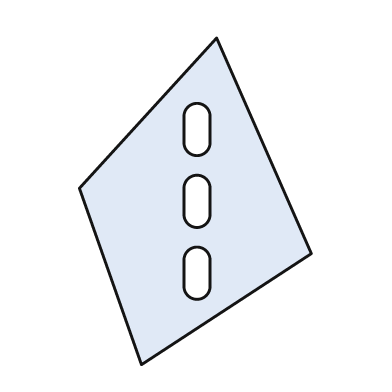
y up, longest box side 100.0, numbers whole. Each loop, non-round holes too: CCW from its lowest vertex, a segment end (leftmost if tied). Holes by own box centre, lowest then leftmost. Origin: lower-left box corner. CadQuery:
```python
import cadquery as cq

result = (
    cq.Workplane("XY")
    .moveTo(19.0, 0.0)
    .lineTo(71.0, 34.0)
    .lineTo(42.0, 100.0)
    .lineTo(0.0, 54.0)
    .close()
    .moveTo(32.0, 24.0)
    .threePointArc((36.0, 20.0), (40.0, 24.0))
    .lineTo(40.0, 32.0)
    .threePointArc((36.0, 36.0), (32.0, 32.0))
    .close()
    .moveTo(32.0, 46.0)
    .threePointArc((36.0, 42.0), (40.0, 46.0))
    .lineTo(40.0, 54.0)
    .threePointArc((36.0, 58.0), (32.0, 54.0))
    .close()
    .moveTo(32.0, 68.0)
    .threePointArc((36.0, 64.0), (40.0, 68.0))
    .lineTo(40.0, 76.0)
    .threePointArc((36.0, 80.0), (32.0, 76.0))
    .close()
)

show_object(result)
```